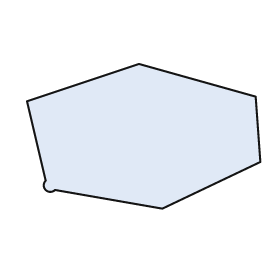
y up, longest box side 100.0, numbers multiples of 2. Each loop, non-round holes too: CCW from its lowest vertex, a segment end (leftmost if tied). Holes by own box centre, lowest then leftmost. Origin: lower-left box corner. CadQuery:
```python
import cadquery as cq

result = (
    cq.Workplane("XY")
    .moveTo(58.0, 0.0)
    .lineTo(100.0, 20.0)
    .lineTo(98.0, 48.0)
    .lineTo(48.0, 62.0)
    .lineTo(0.0, 46.0)
    .lineTo(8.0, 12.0)
    .threePointArc((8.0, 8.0), (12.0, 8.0))
    .close()
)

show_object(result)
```